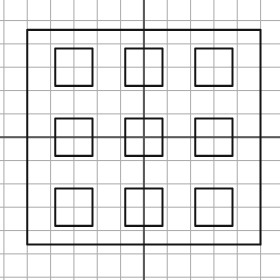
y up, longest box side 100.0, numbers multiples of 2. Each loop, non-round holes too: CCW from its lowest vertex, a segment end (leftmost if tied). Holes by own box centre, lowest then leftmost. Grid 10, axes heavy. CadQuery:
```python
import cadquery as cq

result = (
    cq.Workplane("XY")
    .moveTo(-50.0, -46.0)
    .lineTo(50.0, -46.0)
    .lineTo(50.0, 46.0)
    .lineTo(-50.0, 46.0)
    .close()
    .moveTo(-38.0, -38.0)
    .lineTo(-22.0, -38.0)
    .lineTo(-22.0, -22.0)
    .lineTo(-38.0, -22.0)
    .close()
    .moveTo(-8.0, -38.0)
    .lineTo(8.0, -38.0)
    .lineTo(8.0, -22.0)
    .lineTo(-8.0, -22.0)
    .close()
    .moveTo(22.0, -38.0)
    .lineTo(38.0, -38.0)
    .lineTo(38.0, -22.0)
    .lineTo(22.0, -22.0)
    .close()
    .moveTo(-38.0, -8.0)
    .lineTo(-22.0, -8.0)
    .lineTo(-22.0, 8.0)
    .lineTo(-38.0, 8.0)
    .close()
    .moveTo(-8.0, -8.0)
    .lineTo(8.0, -8.0)
    .lineTo(8.0, 8.0)
    .lineTo(-8.0, 8.0)
    .close()
    .moveTo(22.0, -8.0)
    .lineTo(38.0, -8.0)
    .lineTo(38.0, 8.0)
    .lineTo(22.0, 8.0)
    .close()
    .moveTo(-38.0, 22.0)
    .lineTo(-22.0, 22.0)
    .lineTo(-22.0, 38.0)
    .lineTo(-38.0, 38.0)
    .close()
    .moveTo(-8.0, 22.0)
    .lineTo(8.0, 22.0)
    .lineTo(8.0, 38.0)
    .lineTo(-8.0, 38.0)
    .close()
    .moveTo(22.0, 22.0)
    .lineTo(38.0, 22.0)
    .lineTo(38.0, 38.0)
    .lineTo(22.0, 38.0)
    .close()
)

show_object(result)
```